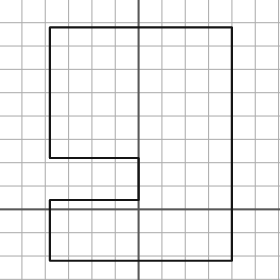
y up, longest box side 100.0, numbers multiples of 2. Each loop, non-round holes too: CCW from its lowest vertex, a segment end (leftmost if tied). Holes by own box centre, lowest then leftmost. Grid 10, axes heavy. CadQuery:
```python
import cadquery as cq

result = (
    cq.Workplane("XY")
    .moveTo(-38.0, -22.0)
    .lineTo(40.0, -22.0)
    .lineTo(40.0, 78.0)
    .lineTo(-38.0, 78.0)
    .lineTo(-38.0, 22.0)
    .lineTo(0.0, 22.0)
    .lineTo(0.0, 4.0)
    .lineTo(-38.0, 4.0)
    .close()
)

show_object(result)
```